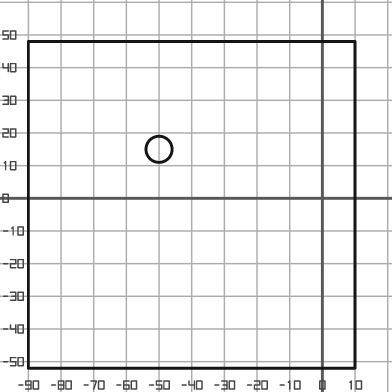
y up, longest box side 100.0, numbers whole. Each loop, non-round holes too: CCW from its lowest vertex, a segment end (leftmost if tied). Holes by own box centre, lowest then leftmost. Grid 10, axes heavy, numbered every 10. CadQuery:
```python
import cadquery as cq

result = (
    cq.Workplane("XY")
    .moveTo(-90.0, -52.0)
    .lineTo(10.0, -52.0)
    .lineTo(10.0, 48.0)
    .lineTo(-90.0, 48.0)
    .close()
    .moveTo(-50.0, 15.0)
    .circle(4.0)
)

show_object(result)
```